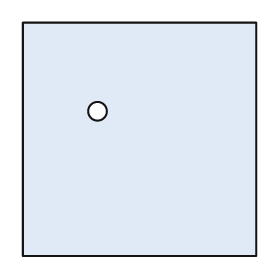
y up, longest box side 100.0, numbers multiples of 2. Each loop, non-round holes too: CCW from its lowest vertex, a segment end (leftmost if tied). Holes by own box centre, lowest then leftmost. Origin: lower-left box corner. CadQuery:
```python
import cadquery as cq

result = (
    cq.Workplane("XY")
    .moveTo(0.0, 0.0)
    .lineTo(100.0, 0.0)
    .lineTo(100.0, 100.0)
    .lineTo(0.0, 100.0)
    .close()
    .moveTo(32.0, 62.0)
    .circle(4.0)
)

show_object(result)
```